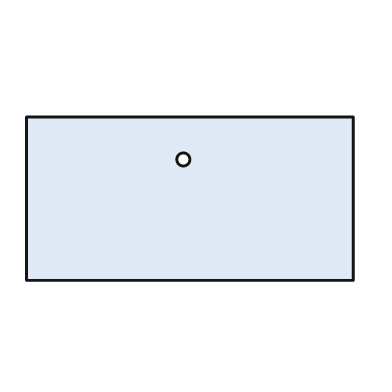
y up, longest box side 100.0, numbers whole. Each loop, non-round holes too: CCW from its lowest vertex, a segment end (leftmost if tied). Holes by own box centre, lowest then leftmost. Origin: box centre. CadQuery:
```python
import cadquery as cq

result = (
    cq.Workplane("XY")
    .moveTo(-50.0, -25.0)
    .lineTo(50.0, -25.0)
    .lineTo(50.0, 25.0)
    .lineTo(-50.0, 25.0)
    .close()
    .moveTo(-2.0, 12.0)
    .circle(2.0)
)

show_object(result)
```